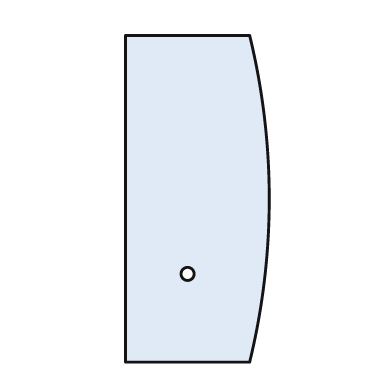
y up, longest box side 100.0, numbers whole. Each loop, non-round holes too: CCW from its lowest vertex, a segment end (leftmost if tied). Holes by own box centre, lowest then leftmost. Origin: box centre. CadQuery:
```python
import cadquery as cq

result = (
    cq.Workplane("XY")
    .moveTo(-22.0, -50.0)
    .lineTo(16.0, -50.0)
    .threePointArc((22.0, 0.0), (16.0, 50.0))
    .lineTo(-22.0, 50.0)
    .close()
    .moveTo(-3.0, -23.0)
    .circle(2.0)
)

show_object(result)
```